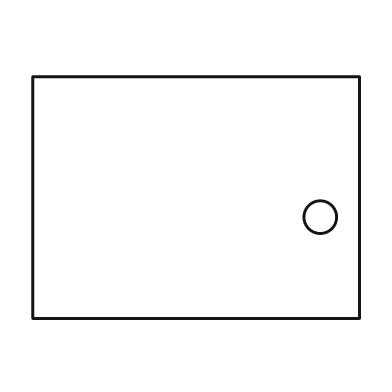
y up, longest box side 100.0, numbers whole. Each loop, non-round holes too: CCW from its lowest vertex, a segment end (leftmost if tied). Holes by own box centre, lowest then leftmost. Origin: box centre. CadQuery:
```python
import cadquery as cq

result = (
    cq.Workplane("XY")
    .moveTo(-50.0, -37.0)
    .lineTo(50.0, -37.0)
    .lineTo(50.0, 37.0)
    .lineTo(-50.0, 37.0)
    .close()
    .moveTo(38.0, -6.0)
    .circle(5.0)
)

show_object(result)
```